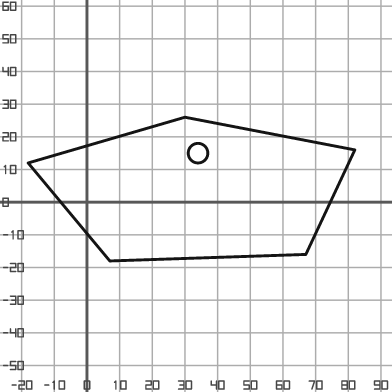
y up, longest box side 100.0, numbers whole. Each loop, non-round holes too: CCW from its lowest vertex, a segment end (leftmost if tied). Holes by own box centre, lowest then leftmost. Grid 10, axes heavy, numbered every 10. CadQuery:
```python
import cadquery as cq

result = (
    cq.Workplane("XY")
    .moveTo(7.0, -18.0)
    .lineTo(67.0, -16.0)
    .lineTo(82.0, 16.0)
    .lineTo(30.0, 26.0)
    .lineTo(-18.0, 12.0)
    .close()
    .moveTo(34.0, 15.0)
    .circle(3.0)
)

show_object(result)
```